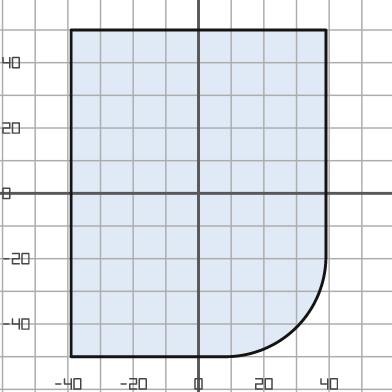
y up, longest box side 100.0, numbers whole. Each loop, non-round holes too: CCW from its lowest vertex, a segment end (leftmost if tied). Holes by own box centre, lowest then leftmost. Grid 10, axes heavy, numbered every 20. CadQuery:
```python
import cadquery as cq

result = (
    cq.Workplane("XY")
    .moveTo(-39.0, -50.0)
    .lineTo(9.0, -50.0)
    .threePointArc((30.0, -41.0), (39.0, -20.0))
    .lineTo(39.0, 50.0)
    .lineTo(-39.0, 50.0)
    .close()
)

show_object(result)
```